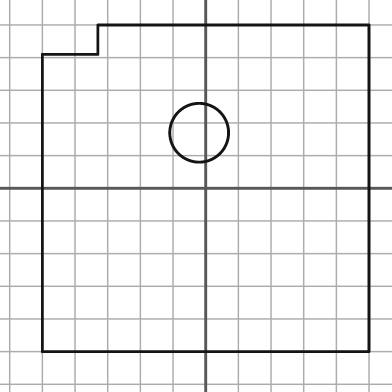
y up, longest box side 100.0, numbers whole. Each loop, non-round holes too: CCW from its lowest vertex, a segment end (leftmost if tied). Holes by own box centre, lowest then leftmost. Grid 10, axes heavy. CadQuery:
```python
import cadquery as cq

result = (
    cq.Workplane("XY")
    .moveTo(-50.0, -50.0)
    .lineTo(50.0, -50.0)
    .lineTo(50.0, 50.0)
    .lineTo(-33.0, 50.0)
    .lineTo(-33.0, 41.0)
    .lineTo(-50.0, 41.0)
    .close()
    .moveTo(-2.0, 17.0)
    .circle(9.0)
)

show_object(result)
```